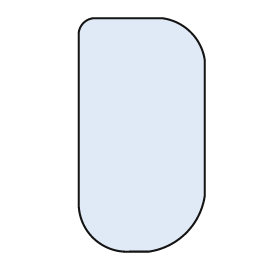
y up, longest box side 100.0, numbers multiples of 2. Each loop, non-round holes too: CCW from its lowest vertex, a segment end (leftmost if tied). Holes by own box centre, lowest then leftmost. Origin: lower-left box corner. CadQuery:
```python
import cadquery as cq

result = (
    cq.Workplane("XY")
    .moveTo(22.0, 0.0)
    .lineTo(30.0, 0.0)
    .threePointArc((46.0, 8.0), (54.0, 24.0))
    .lineTo(54.0, 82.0)
    .threePointArc((48.0, 94.0), (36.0, 100.0))
    .lineTo(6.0, 100.0)
    .threePointArc((2.0, 98.0), (0.0, 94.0))
    .lineTo(0.0, 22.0)
    .threePointArc((6.0, 6.0), (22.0, 0.0))
    .close()
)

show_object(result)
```